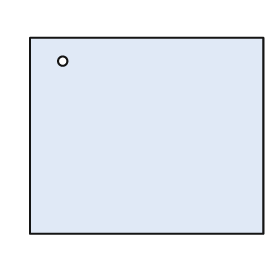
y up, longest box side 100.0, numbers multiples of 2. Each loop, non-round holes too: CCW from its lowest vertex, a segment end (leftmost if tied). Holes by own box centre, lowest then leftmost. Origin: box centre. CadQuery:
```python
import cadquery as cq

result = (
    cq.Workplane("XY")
    .moveTo(-50.0, -42.0)
    .lineTo(50.0, -42.0)
    .lineTo(50.0, 42.0)
    .lineTo(-50.0, 42.0)
    .close()
    .moveTo(-36.0, 32.0)
    .circle(2.0)
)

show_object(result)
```